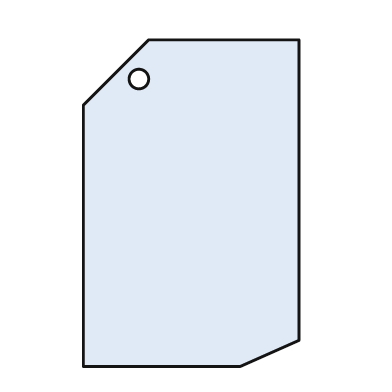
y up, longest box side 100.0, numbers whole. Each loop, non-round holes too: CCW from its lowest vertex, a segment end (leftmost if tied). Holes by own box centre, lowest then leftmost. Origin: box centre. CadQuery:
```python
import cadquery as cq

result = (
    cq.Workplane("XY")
    .moveTo(-33.0, -50.0)
    .lineTo(15.0, -50.0)
    .lineTo(33.0, -42.0)
    .lineTo(33.0, 50.0)
    .lineTo(-13.0, 50.0)
    .lineTo(-33.0, 30.0)
    .close()
    .moveTo(-16.0, 38.0)
    .circle(3.0)
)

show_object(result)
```